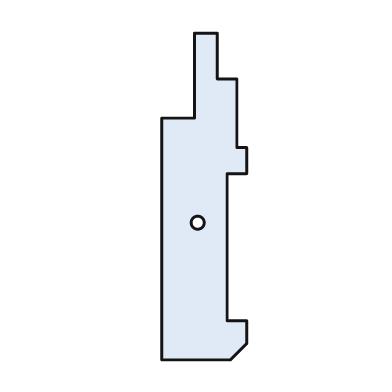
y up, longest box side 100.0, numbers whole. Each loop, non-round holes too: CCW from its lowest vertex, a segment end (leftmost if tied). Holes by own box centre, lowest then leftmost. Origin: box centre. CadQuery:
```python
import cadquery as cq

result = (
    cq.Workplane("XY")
    .moveTo(-13.0, -50.0)
    .lineTo(8.0, -50.0)
    .lineTo(13.0, -45.0)
    .lineTo(13.0, -38.0)
    .lineTo(7.0, -38.0)
    .lineTo(7.0, 7.0)
    .lineTo(13.0, 7.0)
    .lineTo(13.0, 15.0)
    .lineTo(10.0, 15.0)
    .lineTo(10.0, 36.0)
    .lineTo(4.0, 36.0)
    .lineTo(4.0, 50.0)
    .lineTo(-3.0, 50.0)
    .lineTo(-3.0, 24.0)
    .lineTo(-13.0, 24.0)
    .close()
    .moveTo(-2.0, -8.0)
    .circle(2.0)
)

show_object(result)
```